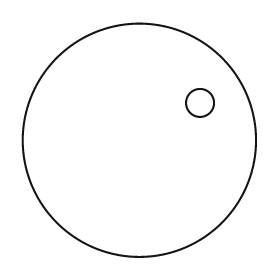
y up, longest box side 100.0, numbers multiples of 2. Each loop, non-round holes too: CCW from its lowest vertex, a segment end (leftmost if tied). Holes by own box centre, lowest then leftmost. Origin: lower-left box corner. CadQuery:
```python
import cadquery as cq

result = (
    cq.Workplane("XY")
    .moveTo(50.0, 50.0)
    .circle(50.0)
    .moveTo(76.0, 66.0)
    .circle(6.0)
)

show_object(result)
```